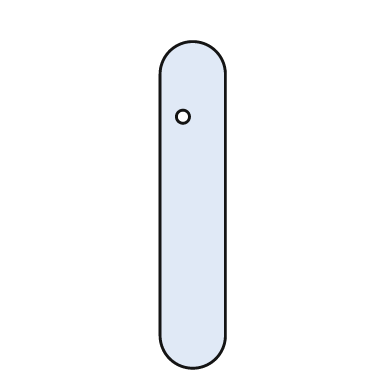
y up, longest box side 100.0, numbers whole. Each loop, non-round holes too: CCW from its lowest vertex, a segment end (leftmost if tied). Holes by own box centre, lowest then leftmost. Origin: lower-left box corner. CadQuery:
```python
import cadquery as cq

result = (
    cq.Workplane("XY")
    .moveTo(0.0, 10.0)
    .threePointArc((10.0, 0.0), (20.0, 10.0))
    .lineTo(20.0, 90.0)
    .threePointArc((10.0, 100.0), (0.0, 90.0))
    .close()
    .moveTo(7.0, 77.0)
    .circle(2.0)
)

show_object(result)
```